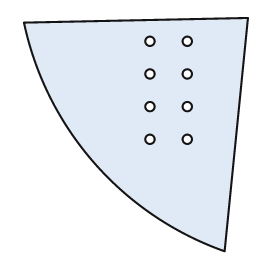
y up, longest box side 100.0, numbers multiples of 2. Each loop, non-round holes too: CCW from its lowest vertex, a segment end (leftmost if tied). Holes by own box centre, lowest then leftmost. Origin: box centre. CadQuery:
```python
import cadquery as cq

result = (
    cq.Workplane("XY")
    .moveTo(38.0, -50.0)
    .lineTo(48.0, 50.0)
    .lineTo(-48.0, 48.0)
    .threePointArc((-18.0, -12.0), (38.0, -50.0))
    .close()
    .moveTo(6.0, -2.0)
    .circle(2.0)
    .moveTo(22.0, -2.0)
    .circle(2.0)
    .moveTo(6.0, 12.0)
    .circle(2.0)
    .moveTo(22.0, 12.0)
    .circle(2.0)
    .moveTo(6.0, 26.0)
    .circle(2.0)
    .moveTo(22.0, 26.0)
    .circle(2.0)
    .moveTo(6.0, 40.0)
    .circle(2.0)
    .moveTo(22.0, 40.0)
    .circle(2.0)
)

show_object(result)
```